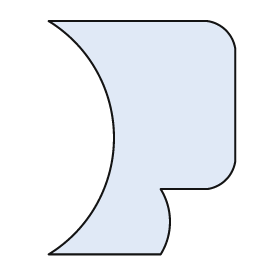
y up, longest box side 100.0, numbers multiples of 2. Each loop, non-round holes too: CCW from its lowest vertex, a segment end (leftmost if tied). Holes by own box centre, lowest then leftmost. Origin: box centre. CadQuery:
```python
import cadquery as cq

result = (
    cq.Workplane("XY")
    .moveTo(-40.0, -50.0)
    .lineTo(8.0, -50.0)
    .threePointArc((12.0, -36.0), (8.0, -22.0))
    .lineTo(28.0, -22.0)
    .threePointArc((36.0, -18.0), (40.0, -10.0))
    .lineTo(40.0, 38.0)
    .threePointArc((36.0, 46.0), (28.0, 50.0))
    .lineTo(-40.0, 50.0)
    .threePointArc((-12.0, 0.0), (-40.0, -50.0))
    .close()
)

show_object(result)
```